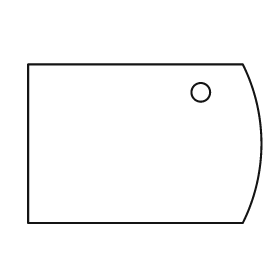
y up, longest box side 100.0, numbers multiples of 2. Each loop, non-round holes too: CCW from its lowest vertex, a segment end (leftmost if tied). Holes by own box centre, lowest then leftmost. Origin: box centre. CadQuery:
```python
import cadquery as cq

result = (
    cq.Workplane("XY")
    .moveTo(-50.0, -34.0)
    .lineTo(42.0, -34.0)
    .threePointArc((50.0, 0.0), (42.0, 34.0))
    .lineTo(-50.0, 34.0)
    .close()
    .moveTo(24.0, 22.0)
    .circle(4.0)
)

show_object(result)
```